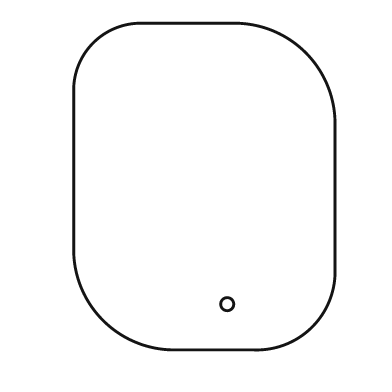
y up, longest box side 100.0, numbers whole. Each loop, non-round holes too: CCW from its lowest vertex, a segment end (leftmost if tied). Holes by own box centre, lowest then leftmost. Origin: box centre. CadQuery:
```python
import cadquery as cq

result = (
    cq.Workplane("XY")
    .moveTo(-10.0, -50.0)
    .lineTo(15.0, -50.0)
    .threePointArc((33.0, -43.0), (40.0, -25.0))
    .lineTo(40.0, 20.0)
    .threePointArc((31.0, 41.0), (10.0, 50.0))
    .lineTo(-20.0, 50.0)
    .threePointArc((-34.0, 44.0), (-40.0, 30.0))
    .lineTo(-40.0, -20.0)
    .threePointArc((-31.0, -41.0), (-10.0, -50.0))
    .close()
    .moveTo(7.0, -36.0)
    .circle(2.0)
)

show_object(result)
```